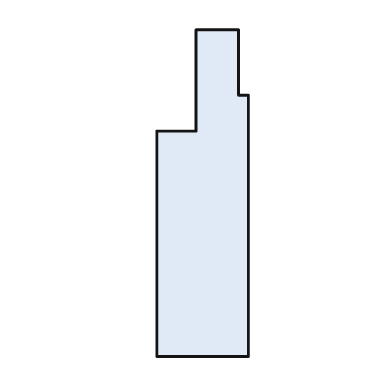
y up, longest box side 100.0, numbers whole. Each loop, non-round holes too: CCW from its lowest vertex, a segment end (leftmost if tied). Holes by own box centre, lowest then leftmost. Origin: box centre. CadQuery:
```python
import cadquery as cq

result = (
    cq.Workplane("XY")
    .moveTo(-14.0, -50.0)
    .lineTo(14.0, -50.0)
    .lineTo(14.0, 30.0)
    .lineTo(11.0, 30.0)
    .lineTo(11.0, 50.0)
    .lineTo(-2.0, 50.0)
    .lineTo(-2.0, 19.0)
    .lineTo(-14.0, 19.0)
    .close()
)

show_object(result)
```